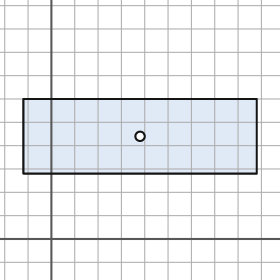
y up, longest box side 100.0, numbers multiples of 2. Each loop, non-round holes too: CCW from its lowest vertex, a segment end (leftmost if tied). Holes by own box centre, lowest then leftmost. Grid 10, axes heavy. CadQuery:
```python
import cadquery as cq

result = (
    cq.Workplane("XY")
    .moveTo(-12.0, 28.0)
    .lineTo(88.0, 28.0)
    .lineTo(88.0, 60.0)
    .lineTo(-12.0, 60.0)
    .close()
    .moveTo(38.0, 44.0)
    .circle(2.0)
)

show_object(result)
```